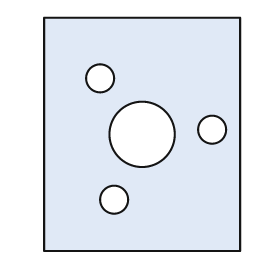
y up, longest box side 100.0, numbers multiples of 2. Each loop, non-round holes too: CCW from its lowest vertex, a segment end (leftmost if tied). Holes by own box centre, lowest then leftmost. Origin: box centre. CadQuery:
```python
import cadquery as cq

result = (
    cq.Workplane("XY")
    .moveTo(-42.0, -50.0)
    .lineTo(42.0, -50.0)
    .lineTo(42.0, 50.0)
    .lineTo(-42.0, 50.0)
    .close()
    .moveTo(-12.0, -28.0)
    .circle(6.0)
    .moveTo(0.0, 0.0)
    .circle(14.0)
    .moveTo(30.0, 2.0)
    .circle(6.0)
    .moveTo(-18.0, 24.0)
    .circle(6.0)
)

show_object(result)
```